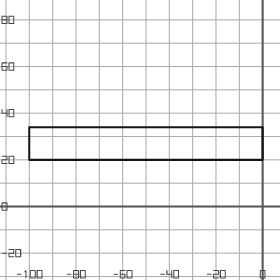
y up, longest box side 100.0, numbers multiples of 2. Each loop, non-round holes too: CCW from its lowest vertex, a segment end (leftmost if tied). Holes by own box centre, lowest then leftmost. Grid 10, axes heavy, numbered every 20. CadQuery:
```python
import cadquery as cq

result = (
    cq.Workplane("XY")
    .moveTo(-100.0, 20.0)
    .lineTo(0.0, 20.0)
    .lineTo(0.0, 34.0)
    .lineTo(-100.0, 34.0)
    .close()
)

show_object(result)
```